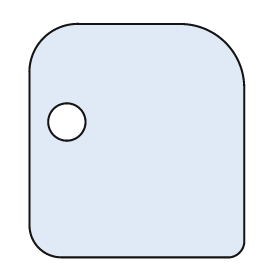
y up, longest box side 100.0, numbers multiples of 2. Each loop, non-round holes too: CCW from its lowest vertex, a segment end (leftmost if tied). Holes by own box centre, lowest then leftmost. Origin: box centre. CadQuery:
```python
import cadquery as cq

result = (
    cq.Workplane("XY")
    .moveTo(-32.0, -50.0)
    .lineTo(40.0, -50.0)
    .threePointArc((44.0, -48.0), (46.0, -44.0))
    .lineTo(46.0, 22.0)
    .threePointArc((38.0, 42.0), (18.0, 50.0))
    .lineTo(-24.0, 50.0)
    .threePointArc((-40.0, 44.0), (-46.0, 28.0))
    .lineTo(-46.0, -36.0)
    .threePointArc((-42.0, -46.0), (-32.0, -50.0))
    .close()
    .moveTo(-30.0, 8.0)
    .circle(8.0)
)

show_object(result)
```